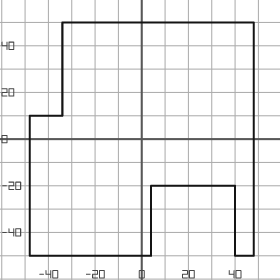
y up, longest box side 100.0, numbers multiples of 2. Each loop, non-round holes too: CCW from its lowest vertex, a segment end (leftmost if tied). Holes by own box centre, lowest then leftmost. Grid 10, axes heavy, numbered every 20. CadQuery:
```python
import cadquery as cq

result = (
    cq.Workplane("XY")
    .moveTo(-48.0, -50.0)
    .lineTo(4.0, -50.0)
    .lineTo(4.0, -20.0)
    .lineTo(40.0, -20.0)
    .lineTo(40.0, -50.0)
    .lineTo(48.0, -50.0)
    .lineTo(48.0, 50.0)
    .lineTo(-34.0, 50.0)
    .lineTo(-34.0, 10.0)
    .lineTo(-48.0, 10.0)
    .close()
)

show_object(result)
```